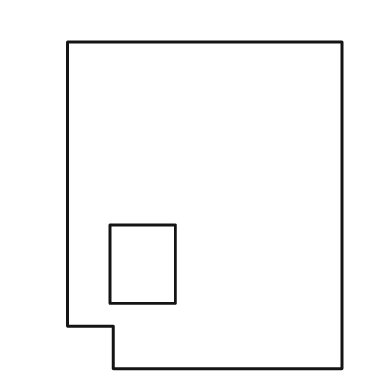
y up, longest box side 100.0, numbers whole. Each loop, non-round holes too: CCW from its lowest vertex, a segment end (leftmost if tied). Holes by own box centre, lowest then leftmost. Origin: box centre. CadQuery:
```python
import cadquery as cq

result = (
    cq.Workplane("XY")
    .moveTo(-28.0, -50.0)
    .lineTo(42.0, -50.0)
    .lineTo(42.0, 50.0)
    .lineTo(-42.0, 50.0)
    .lineTo(-42.0, -37.0)
    .lineTo(-28.0, -37.0)
    .close()
    .moveTo(-29.0, -30.0)
    .lineTo(-9.0, -30.0)
    .lineTo(-9.0, -6.0)
    .lineTo(-29.0, -6.0)
    .close()
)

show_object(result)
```